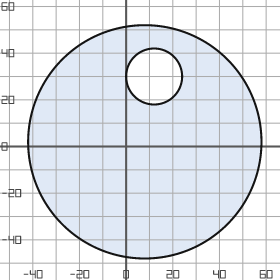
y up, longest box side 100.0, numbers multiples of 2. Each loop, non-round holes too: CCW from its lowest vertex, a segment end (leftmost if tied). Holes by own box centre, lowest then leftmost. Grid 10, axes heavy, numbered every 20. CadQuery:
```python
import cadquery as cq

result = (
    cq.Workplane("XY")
    .moveTo(8.0, 2.0)
    .circle(50.0)
    .moveTo(12.0, 30.0)
    .circle(12.0)
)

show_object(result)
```